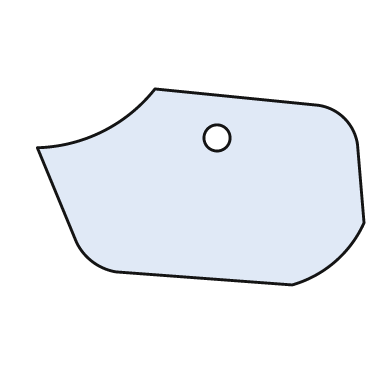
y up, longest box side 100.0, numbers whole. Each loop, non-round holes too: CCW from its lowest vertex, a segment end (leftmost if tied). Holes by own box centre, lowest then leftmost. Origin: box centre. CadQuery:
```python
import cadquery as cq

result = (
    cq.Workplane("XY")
    .moveTo(28.0, -30.0)
    .threePointArc((41.0, -23.0), (50.0, -11.0))
    .lineTo(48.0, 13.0)
    .threePointArc((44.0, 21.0), (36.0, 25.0))
    .lineTo(-14.0, 30.0)
    .threePointArc((-30.0, 17.0), (-50.0, 12.0))
    .lineTo(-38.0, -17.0)
    .threePointArc((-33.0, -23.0), (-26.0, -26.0))
    .close()
    .moveTo(5.0, 15.0)
    .circle(4.0)
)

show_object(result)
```